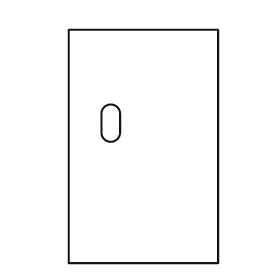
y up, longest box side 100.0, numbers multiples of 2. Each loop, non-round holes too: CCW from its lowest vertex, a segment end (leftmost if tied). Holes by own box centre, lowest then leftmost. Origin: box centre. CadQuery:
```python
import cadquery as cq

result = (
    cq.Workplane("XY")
    .moveTo(-32.0, -50.0)
    .lineTo(32.0, -50.0)
    .lineTo(32.0, 50.0)
    .lineTo(-32.0, 50.0)
    .close()
    .moveTo(-18.0, 6.0)
    .threePointArc((-14.0, 2.0), (-10.0, 6.0))
    .lineTo(-10.0, 14.0)
    .threePointArc((-14.0, 18.0), (-18.0, 14.0))
    .close()
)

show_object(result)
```